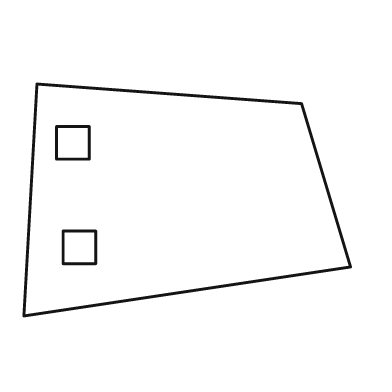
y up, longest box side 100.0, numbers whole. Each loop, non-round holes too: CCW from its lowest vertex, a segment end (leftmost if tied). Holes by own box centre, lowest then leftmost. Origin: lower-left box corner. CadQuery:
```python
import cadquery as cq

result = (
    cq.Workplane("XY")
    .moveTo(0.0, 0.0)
    .lineTo(100.0, 15.0)
    .lineTo(85.0, 65.0)
    .lineTo(4.0, 71.0)
    .close()
    .moveTo(12.0, 16.0)
    .lineTo(22.0, 16.0)
    .lineTo(22.0, 26.0)
    .lineTo(12.0, 26.0)
    .close()
    .moveTo(10.0, 48.0)
    .lineTo(20.0, 48.0)
    .lineTo(20.0, 58.0)
    .lineTo(10.0, 58.0)
    .close()
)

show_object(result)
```